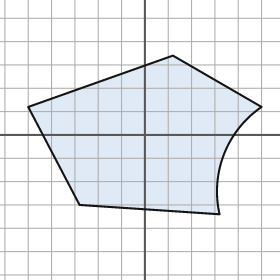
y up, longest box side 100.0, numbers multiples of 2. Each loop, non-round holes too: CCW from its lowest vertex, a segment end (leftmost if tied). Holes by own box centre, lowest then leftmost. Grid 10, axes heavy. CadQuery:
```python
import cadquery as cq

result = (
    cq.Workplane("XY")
    .moveTo(32.0, -34.0)
    .threePointArc((34.0, -8.0), (50.0, 12.0))
    .lineTo(12.0, 34.0)
    .lineTo(-50.0, 12.0)
    .lineTo(-28.0, -30.0)
    .close()
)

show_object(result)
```